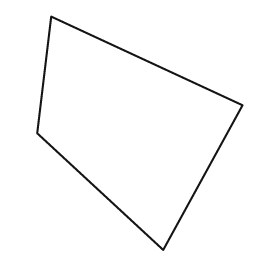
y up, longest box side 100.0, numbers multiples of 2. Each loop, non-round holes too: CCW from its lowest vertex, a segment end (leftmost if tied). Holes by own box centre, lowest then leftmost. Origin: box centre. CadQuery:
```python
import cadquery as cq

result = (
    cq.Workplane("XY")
    .moveTo(10.0, -50.0)
    .lineTo(44.0, 12.0)
    .lineTo(-38.0, 50.0)
    .lineTo(-44.0, 0.0)
    .close()
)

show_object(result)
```